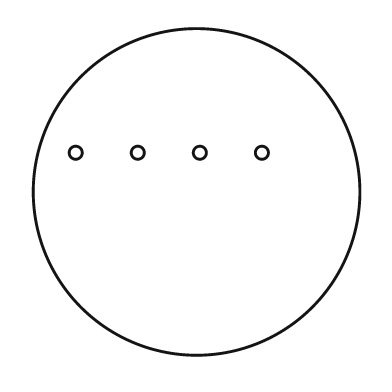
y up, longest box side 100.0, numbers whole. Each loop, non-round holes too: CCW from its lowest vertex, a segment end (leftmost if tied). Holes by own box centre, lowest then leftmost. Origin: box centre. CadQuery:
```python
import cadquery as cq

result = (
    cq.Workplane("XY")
    .moveTo(0.0, 0.0)
    .circle(50.0)
    .moveTo(-37.0, 12.0)
    .circle(2.0)
    .moveTo(-18.0, 12.0)
    .circle(2.0)
    .moveTo(1.0, 12.0)
    .circle(2.0)
    .moveTo(20.0, 12.0)
    .circle(2.0)
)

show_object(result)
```